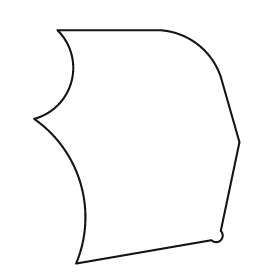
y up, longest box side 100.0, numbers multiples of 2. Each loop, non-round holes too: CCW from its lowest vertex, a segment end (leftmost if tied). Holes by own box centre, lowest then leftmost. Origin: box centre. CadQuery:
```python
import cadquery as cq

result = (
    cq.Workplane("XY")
    .moveTo(-26.0, -50.0)
    .lineTo(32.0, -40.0)
    .threePointArc((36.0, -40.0), (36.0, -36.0))
    .lineTo(44.0, 2.0)
    .lineTo(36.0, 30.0)
    .threePointArc((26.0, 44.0), (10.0, 50.0))
    .lineTo(-34.0, 50.0)
    .threePointArc((-28.0, 28.0), (-44.0, 12.0))
    .threePointArc((-24.0, -16.0), (-26.0, -50.0))
    .close()
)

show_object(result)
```